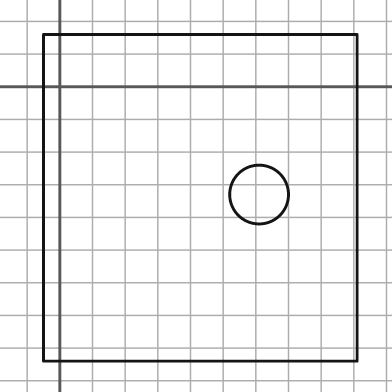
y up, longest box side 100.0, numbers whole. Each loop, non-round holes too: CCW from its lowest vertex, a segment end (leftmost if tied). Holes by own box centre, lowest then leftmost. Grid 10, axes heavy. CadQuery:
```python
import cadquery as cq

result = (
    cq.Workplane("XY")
    .moveTo(-5.0, -84.0)
    .lineTo(91.0, -84.0)
    .lineTo(91.0, 16.0)
    .lineTo(-5.0, 16.0)
    .close()
    .moveTo(61.0, -33.0)
    .circle(9.0)
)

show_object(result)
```